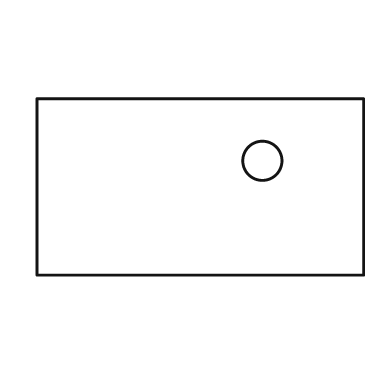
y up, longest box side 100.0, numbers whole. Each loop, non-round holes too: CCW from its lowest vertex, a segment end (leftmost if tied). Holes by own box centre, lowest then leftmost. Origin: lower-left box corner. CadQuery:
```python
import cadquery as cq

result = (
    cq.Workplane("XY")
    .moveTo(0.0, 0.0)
    .lineTo(100.0, 0.0)
    .lineTo(100.0, 54.0)
    .lineTo(0.0, 54.0)
    .close()
    .moveTo(69.0, 35.0)
    .circle(6.0)
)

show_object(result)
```